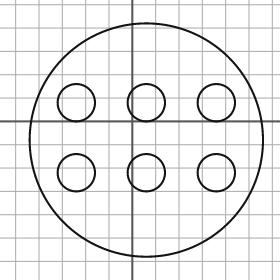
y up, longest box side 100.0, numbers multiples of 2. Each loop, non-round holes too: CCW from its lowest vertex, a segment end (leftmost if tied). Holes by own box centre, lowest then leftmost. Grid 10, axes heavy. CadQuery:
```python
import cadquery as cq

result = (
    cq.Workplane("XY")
    .moveTo(6.0, -8.0)
    .circle(50.0)
    .moveTo(-24.0, -22.0)
    .circle(8.0)
    .moveTo(6.0, -22.0)
    .circle(8.0)
    .moveTo(36.0, -22.0)
    .circle(8.0)
    .moveTo(-24.0, 8.0)
    .circle(8.0)
    .moveTo(6.0, 8.0)
    .circle(8.0)
    .moveTo(36.0, 8.0)
    .circle(8.0)
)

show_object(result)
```